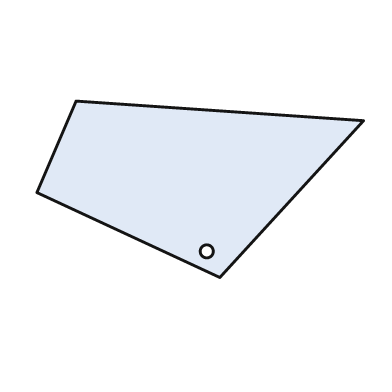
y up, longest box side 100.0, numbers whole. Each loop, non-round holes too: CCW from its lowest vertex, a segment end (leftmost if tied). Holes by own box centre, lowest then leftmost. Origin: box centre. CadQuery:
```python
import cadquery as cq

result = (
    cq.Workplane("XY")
    .moveTo(6.0, -27.0)
    .lineTo(50.0, 21.0)
    .lineTo(-38.0, 27.0)
    .lineTo(-50.0, -1.0)
    .close()
    .moveTo(2.0, -19.0)
    .circle(2.0)
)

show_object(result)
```